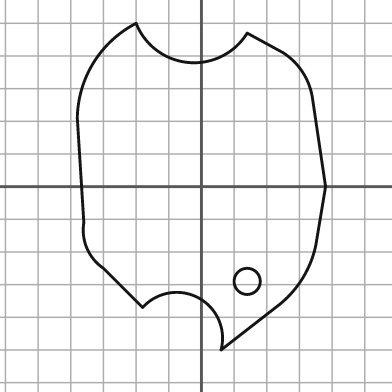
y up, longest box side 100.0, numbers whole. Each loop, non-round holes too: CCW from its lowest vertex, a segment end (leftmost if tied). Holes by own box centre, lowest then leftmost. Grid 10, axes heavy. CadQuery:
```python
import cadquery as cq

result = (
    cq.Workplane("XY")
    .moveTo(6.0, -50.0)
    .lineTo(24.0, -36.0)
    .threePointArc((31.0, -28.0), (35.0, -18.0))
    .lineTo(38.0, 0.0)
    .lineTo(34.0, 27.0)
    .threePointArc((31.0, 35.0), (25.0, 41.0))
    .lineTo(14.0, 47.0)
    .threePointArc((-4.0, 38.0), (-20.0, 50.0))
    .threePointArc((-33.0, 38.0), (-38.0, 21.0))
    .lineTo(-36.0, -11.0)
    .threePointArc((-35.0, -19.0), (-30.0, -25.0))
    .lineTo(-18.0, -37.0)
    .threePointArc((-1.0, -34.0), (6.0, -50.0))
    .close()
    .moveTo(14.0, -29.0)
    .circle(4.0)
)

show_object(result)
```